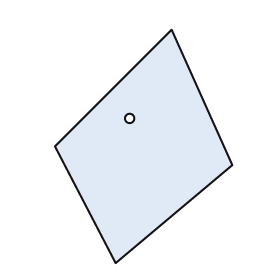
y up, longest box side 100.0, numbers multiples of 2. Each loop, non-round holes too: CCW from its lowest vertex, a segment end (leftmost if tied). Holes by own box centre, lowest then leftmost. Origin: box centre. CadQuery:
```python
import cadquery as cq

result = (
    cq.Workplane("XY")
    .moveTo(-12.0, -50.0)
    .lineTo(38.0, -8.0)
    .lineTo(12.0, 50.0)
    .lineTo(-38.0, 0.0)
    .close()
    .moveTo(-6.0, 12.0)
    .circle(2.0)
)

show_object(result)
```